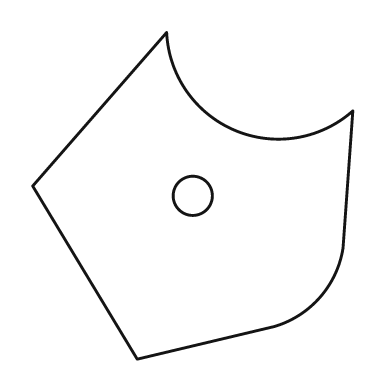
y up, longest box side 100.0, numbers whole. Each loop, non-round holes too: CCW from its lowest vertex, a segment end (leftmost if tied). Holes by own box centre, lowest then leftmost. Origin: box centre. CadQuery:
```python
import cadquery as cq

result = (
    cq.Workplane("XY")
    .moveTo(-17.0, -50.0)
    .lineTo(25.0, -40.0)
    .threePointArc((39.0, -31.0), (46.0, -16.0))
    .lineTo(49.0, 26.0)
    .threePointArc((13.0, 20.0), (-8.0, 50.0))
    .lineTo(-49.0, 3.0)
    .close()
    .moveTo(0.0, 0.0)
    .circle(6.0)
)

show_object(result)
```